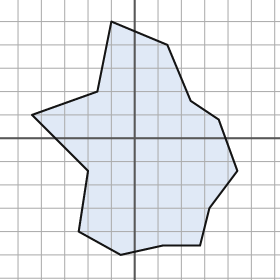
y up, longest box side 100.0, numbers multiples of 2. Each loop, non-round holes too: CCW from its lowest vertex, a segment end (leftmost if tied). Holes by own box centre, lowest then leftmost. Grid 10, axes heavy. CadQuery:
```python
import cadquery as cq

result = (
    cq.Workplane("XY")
    .moveTo(-6.0, -50.0)
    .lineTo(12.0, -46.0)
    .lineTo(28.0, -46.0)
    .lineTo(32.0, -30.0)
    .lineTo(44.0, -14.0)
    .lineTo(36.0, 8.0)
    .lineTo(24.0, 16.0)
    .lineTo(14.0, 40.0)
    .lineTo(-10.0, 50.0)
    .lineTo(-16.0, 20.0)
    .lineTo(-44.0, 10.0)
    .lineTo(-20.0, -14.0)
    .lineTo(-24.0, -40.0)
    .close()
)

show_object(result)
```